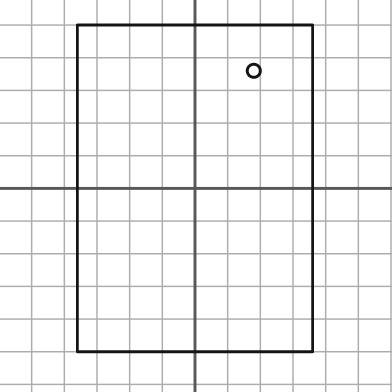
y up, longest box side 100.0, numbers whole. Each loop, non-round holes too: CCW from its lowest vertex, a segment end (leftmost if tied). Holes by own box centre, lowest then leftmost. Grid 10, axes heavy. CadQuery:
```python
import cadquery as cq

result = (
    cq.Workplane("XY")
    .moveTo(-36.0, -50.0)
    .lineTo(36.0, -50.0)
    .lineTo(36.0, 50.0)
    .lineTo(-36.0, 50.0)
    .close()
    .moveTo(18.0, 36.0)
    .circle(2.0)
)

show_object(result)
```